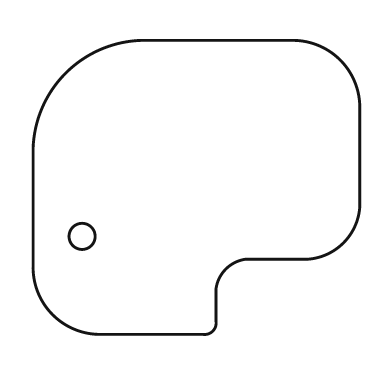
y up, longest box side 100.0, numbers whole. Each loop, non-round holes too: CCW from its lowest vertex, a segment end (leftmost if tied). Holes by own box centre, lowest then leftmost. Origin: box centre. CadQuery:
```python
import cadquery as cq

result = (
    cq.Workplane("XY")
    .moveTo(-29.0, -45.0)
    .lineTo(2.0, -45.0)
    .threePointArc((5.0, -44.0), (6.0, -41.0))
    .lineTo(6.0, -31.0)
    .threePointArc((9.0, -25.0), (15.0, -22.0))
    .lineTo(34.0, -22.0)
    .threePointArc((45.0, -17.0), (50.0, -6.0))
    .lineTo(50.0, 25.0)
    .threePointArc((44.0, 39.0), (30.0, 45.0))
    .lineTo(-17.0, 45.0)
    .threePointArc((-40.0, 35.0), (-50.0, 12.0))
    .lineTo(-50.0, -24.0)
    .threePointArc((-44.0, -39.0), (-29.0, -45.0))
    .close()
    .moveTo(-35.0, -15.0)
    .circle(4.0)
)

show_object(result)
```